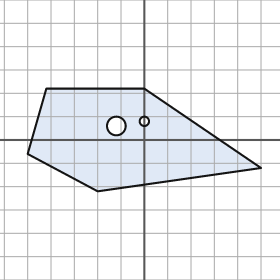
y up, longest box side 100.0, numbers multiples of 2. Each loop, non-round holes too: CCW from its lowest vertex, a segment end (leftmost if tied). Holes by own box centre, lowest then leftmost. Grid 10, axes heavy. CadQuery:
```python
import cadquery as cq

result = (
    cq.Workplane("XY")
    .moveTo(-20.0, -22.0)
    .lineTo(50.0, -12.0)
    .lineTo(0.0, 22.0)
    .lineTo(-42.0, 22.0)
    .lineTo(-50.0, -6.0)
    .close()
    .moveTo(-12.0, 6.0)
    .circle(4.0)
    .moveTo(0.0, 8.0)
    .circle(2.0)
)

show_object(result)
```